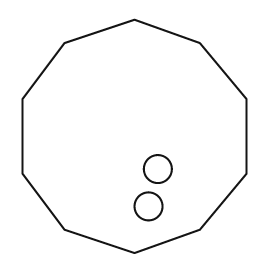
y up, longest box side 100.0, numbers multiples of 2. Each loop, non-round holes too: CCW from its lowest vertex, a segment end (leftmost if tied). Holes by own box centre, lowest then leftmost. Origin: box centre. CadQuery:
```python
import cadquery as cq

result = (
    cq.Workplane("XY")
    .moveTo(0.0, -50.0)
    .lineTo(28.0, -40.0)
    .lineTo(48.0, -16.0)
    .lineTo(48.0, 16.0)
    .lineTo(28.0, 40.0)
    .lineTo(0.0, 50.0)
    .lineTo(-30.0, 40.0)
    .lineTo(-48.0, 16.0)
    .lineTo(-48.0, -16.0)
    .lineTo(-30.0, -40.0)
    .close()
    .moveTo(6.0, -30.0)
    .circle(6.0)
    .moveTo(10.0, -14.0)
    .circle(6.0)
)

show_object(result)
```